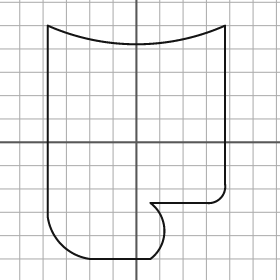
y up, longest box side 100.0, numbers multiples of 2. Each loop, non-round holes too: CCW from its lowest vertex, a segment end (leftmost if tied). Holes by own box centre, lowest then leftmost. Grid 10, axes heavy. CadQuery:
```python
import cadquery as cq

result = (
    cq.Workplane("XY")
    .moveTo(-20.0, -50.0)
    .lineTo(6.0, -50.0)
    .threePointArc((12.0, -38.0), (6.0, -26.0))
    .lineTo(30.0, -26.0)
    .threePointArc((36.0, -24.0), (38.0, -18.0))
    .lineTo(38.0, 50.0)
    .threePointArc((0.0, 42.0), (-38.0, 50.0))
    .lineTo(-38.0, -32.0)
    .threePointArc((-32.0, -44.0), (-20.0, -50.0))
    .close()
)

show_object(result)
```